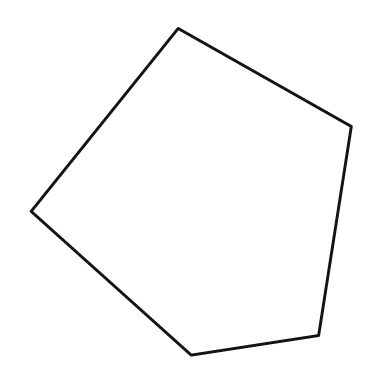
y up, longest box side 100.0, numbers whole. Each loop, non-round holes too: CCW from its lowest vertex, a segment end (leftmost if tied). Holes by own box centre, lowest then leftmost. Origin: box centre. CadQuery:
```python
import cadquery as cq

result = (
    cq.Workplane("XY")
    .moveTo(0.0, -50.0)
    .lineTo(39.0, -44.0)
    .lineTo(49.0, 20.0)
    .lineTo(-4.0, 50.0)
    .lineTo(-49.0, -6.0)
    .close()
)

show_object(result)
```